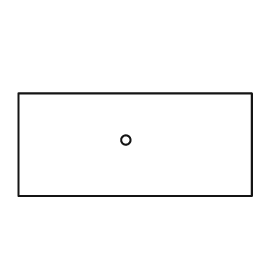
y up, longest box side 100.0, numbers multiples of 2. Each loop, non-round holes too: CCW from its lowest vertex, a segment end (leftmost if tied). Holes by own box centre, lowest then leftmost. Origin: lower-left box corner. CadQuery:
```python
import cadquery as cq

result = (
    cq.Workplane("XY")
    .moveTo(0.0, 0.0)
    .lineTo(100.0, 0.0)
    .lineTo(100.0, 44.0)
    .lineTo(0.0, 44.0)
    .close()
    .moveTo(46.0, 24.0)
    .circle(2.0)
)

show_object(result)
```